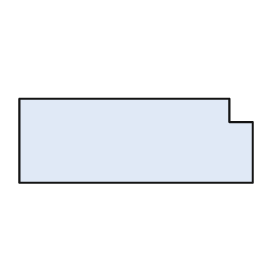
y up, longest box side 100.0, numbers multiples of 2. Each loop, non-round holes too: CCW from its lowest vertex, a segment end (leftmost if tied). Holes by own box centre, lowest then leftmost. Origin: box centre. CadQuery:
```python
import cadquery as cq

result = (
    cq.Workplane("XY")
    .moveTo(-50.0, -18.0)
    .lineTo(50.0, -18.0)
    .lineTo(50.0, 8.0)
    .lineTo(40.0, 8.0)
    .lineTo(40.0, 18.0)
    .lineTo(-50.0, 18.0)
    .close()
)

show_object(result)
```